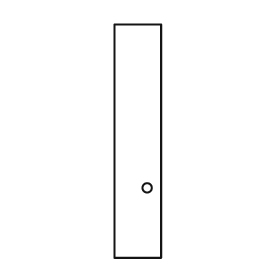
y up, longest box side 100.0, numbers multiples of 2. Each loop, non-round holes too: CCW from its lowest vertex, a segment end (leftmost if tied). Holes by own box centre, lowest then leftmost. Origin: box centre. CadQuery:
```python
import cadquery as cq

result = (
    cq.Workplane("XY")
    .moveTo(-10.0, -50.0)
    .lineTo(10.0, -50.0)
    .lineTo(10.0, 50.0)
    .lineTo(-10.0, 50.0)
    .close()
    .moveTo(4.0, -20.0)
    .circle(2.0)
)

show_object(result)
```